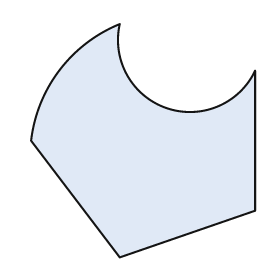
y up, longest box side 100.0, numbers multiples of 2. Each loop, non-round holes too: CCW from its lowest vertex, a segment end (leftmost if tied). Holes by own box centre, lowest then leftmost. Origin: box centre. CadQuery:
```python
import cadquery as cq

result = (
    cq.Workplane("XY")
    .moveTo(-10.0, -50.0)
    .lineTo(48.0, -30.0)
    .lineTo(48.0, 30.0)
    .threePointArc((10.0, 14.0), (-10.0, 50.0))
    .threePointArc((-36.0, 30.0), (-48.0, 0.0))
    .close()
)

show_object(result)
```